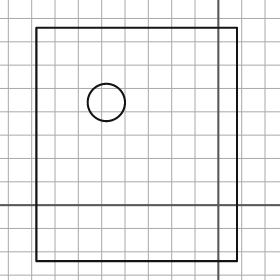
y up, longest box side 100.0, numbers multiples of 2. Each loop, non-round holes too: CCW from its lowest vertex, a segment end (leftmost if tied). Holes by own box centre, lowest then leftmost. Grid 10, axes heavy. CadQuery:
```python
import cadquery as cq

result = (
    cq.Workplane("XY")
    .moveTo(-78.0, -24.0)
    .lineTo(8.0, -24.0)
    .lineTo(8.0, 76.0)
    .lineTo(-78.0, 76.0)
    .close()
    .moveTo(-48.0, 44.0)
    .circle(8.0)
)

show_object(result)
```